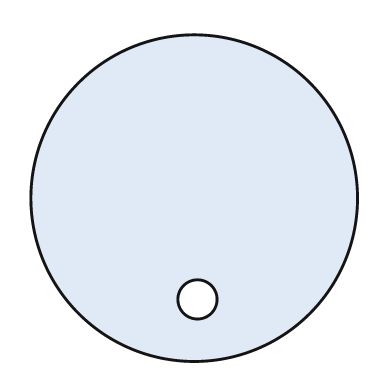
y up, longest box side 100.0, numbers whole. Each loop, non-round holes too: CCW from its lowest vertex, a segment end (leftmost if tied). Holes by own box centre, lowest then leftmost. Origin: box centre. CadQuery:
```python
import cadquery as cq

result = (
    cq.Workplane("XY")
    .moveTo(0.0, 0.0)
    .circle(50.0)
    .moveTo(1.0, -31.0)
    .circle(6.0)
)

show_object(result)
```